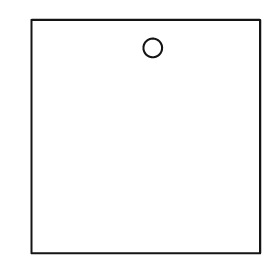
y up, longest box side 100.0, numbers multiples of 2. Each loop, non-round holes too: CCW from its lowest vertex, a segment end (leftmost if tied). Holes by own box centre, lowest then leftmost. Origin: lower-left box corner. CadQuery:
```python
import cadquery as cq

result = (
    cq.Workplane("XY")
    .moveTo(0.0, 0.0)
    .lineTo(98.0, 0.0)
    .lineTo(98.0, 100.0)
    .lineTo(0.0, 100.0)
    .close()
    .moveTo(52.0, 88.0)
    .circle(4.0)
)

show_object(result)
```